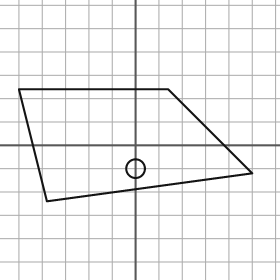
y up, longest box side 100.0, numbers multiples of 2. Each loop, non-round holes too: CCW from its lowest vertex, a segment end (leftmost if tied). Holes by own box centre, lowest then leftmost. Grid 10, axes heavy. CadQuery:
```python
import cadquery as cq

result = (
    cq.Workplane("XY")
    .moveTo(-38.0, -24.0)
    .lineTo(50.0, -12.0)
    .lineTo(14.0, 24.0)
    .lineTo(-50.0, 24.0)
    .close()
    .moveTo(0.0, -10.0)
    .circle(4.0)
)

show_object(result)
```